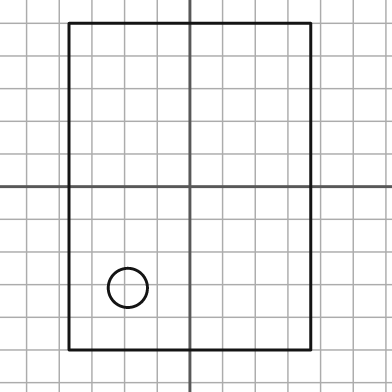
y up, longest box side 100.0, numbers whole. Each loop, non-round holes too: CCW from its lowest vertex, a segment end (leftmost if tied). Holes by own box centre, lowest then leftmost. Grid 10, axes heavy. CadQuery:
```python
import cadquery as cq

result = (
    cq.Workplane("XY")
    .moveTo(-37.0, -50.0)
    .lineTo(37.0, -50.0)
    .lineTo(37.0, 50.0)
    .lineTo(-37.0, 50.0)
    .close()
    .moveTo(-19.0, -31.0)
    .circle(6.0)
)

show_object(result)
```